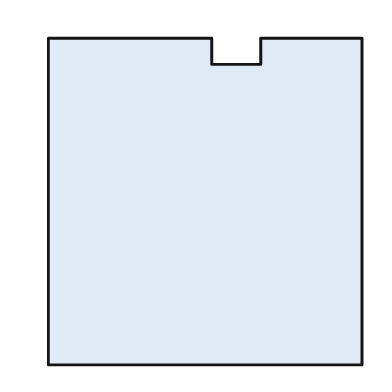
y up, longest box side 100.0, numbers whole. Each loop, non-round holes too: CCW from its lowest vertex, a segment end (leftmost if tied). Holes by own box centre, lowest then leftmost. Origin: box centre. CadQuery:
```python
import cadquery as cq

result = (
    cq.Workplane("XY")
    .moveTo(-48.0, -50.0)
    .lineTo(48.0, -50.0)
    .lineTo(48.0, 50.0)
    .lineTo(17.0, 50.0)
    .lineTo(17.0, 42.0)
    .lineTo(2.0, 42.0)
    .lineTo(2.0, 50.0)
    .lineTo(-48.0, 50.0)
    .close()
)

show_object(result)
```